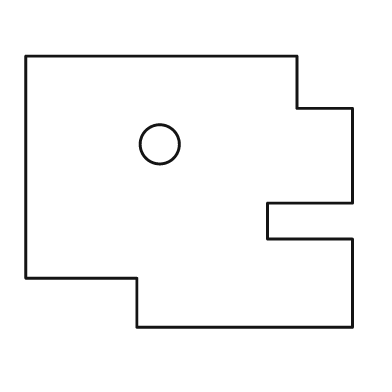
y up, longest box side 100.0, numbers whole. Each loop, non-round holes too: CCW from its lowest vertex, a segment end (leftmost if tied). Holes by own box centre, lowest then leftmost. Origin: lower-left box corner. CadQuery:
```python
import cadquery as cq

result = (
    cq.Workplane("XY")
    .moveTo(34.0, 0.0)
    .lineTo(100.0, 0.0)
    .lineTo(100.0, 27.0)
    .lineTo(74.0, 27.0)
    .lineTo(74.0, 38.0)
    .lineTo(100.0, 38.0)
    .lineTo(100.0, 67.0)
    .lineTo(83.0, 67.0)
    .lineTo(83.0, 83.0)
    .lineTo(0.0, 83.0)
    .lineTo(0.0, 15.0)
    .lineTo(34.0, 15.0)
    .close()
    .moveTo(41.0, 56.0)
    .circle(6.0)
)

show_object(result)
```